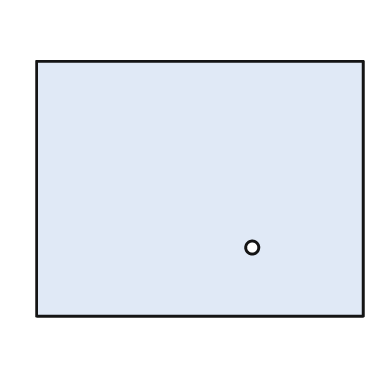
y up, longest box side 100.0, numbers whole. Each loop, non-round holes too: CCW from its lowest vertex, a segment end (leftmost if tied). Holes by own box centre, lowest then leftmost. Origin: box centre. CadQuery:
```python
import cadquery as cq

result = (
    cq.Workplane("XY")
    .moveTo(-50.0, -39.0)
    .lineTo(50.0, -39.0)
    .lineTo(50.0, 39.0)
    .lineTo(-50.0, 39.0)
    .close()
    .moveTo(16.0, -18.0)
    .circle(2.0)
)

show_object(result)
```